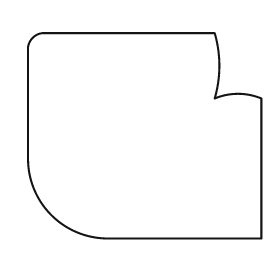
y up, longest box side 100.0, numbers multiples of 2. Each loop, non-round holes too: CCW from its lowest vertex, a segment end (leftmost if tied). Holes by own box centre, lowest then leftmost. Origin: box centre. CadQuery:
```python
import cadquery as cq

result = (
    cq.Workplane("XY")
    .moveTo(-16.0, -44.0)
    .lineTo(50.0, -44.0)
    .lineTo(50.0, 16.0)
    .threePointArc((40.0, 18.0), (30.0, 16.0))
    .threePointArc((32.0, 30.0), (30.0, 44.0))
    .lineTo(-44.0, 44.0)
    .threePointArc((-48.0, 42.0), (-50.0, 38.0))
    .lineTo(-50.0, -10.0)
    .threePointArc((-40.0, -34.0), (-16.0, -44.0))
    .close()
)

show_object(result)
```